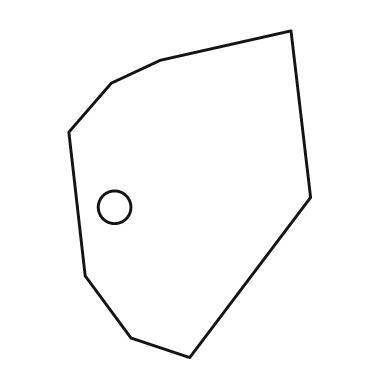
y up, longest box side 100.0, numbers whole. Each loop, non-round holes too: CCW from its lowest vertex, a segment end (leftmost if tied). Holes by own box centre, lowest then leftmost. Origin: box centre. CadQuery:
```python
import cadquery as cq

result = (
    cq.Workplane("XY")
    .moveTo(0.0, -50.0)
    .lineTo(37.0, -1.0)
    .lineTo(31.0, 50.0)
    .lineTo(-9.0, 41.0)
    .lineTo(-24.0, 34.0)
    .lineTo(-37.0, 19.0)
    .lineTo(-32.0, -25.0)
    .lineTo(-18.0, -44.0)
    .close()
    .moveTo(-23.0, -4.0)
    .circle(5.0)
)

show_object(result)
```